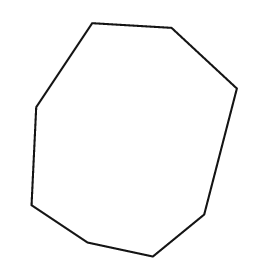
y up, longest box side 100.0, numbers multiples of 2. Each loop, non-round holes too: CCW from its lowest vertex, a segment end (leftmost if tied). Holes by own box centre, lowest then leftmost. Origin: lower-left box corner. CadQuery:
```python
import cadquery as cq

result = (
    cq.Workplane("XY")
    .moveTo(52.0, 0.0)
    .lineTo(74.0, 18.0)
    .lineTo(88.0, 72.0)
    .lineTo(60.0, 98.0)
    .lineTo(26.0, 100.0)
    .lineTo(2.0, 64.0)
    .lineTo(0.0, 22.0)
    .lineTo(24.0, 6.0)
    .close()
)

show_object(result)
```